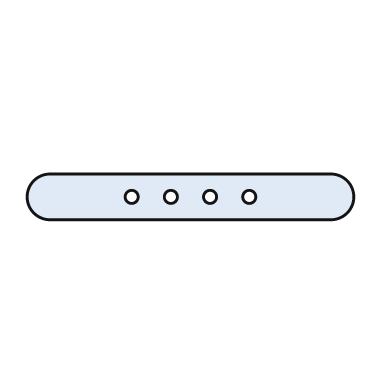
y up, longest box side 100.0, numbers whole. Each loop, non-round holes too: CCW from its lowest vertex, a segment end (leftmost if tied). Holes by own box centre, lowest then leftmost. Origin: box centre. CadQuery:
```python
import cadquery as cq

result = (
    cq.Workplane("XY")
    .moveTo(-43.0, -7.0)
    .lineTo(43.0, -7.0)
    .threePointArc((50.0, 0.0), (43.0, 7.0))
    .lineTo(-43.0, 7.0)
    .threePointArc((-50.0, 0.0), (-43.0, -7.0))
    .close()
    .moveTo(-18.0, 0.0)
    .circle(2.0)
    .moveTo(-6.0, 0.0)
    .circle(2.0)
    .moveTo(6.0, 0.0)
    .circle(2.0)
    .moveTo(18.0, 0.0)
    .circle(2.0)
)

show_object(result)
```